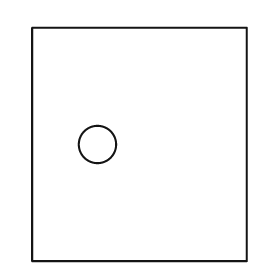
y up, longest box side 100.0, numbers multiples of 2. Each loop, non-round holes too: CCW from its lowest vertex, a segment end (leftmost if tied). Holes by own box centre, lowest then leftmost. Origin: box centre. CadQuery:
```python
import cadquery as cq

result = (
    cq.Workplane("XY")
    .moveTo(-46.0, -50.0)
    .lineTo(46.0, -50.0)
    .lineTo(46.0, 50.0)
    .lineTo(-46.0, 50.0)
    .close()
    .moveTo(-18.0, 0.0)
    .circle(8.0)
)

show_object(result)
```